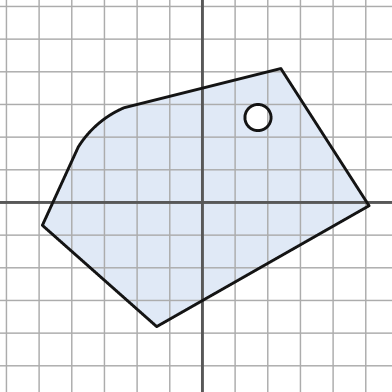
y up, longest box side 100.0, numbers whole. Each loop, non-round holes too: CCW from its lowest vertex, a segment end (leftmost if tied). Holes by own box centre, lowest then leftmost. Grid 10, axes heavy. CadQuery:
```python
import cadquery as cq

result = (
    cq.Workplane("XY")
    .moveTo(-14.0, -38.0)
    .lineTo(51.0, -1.0)
    .lineTo(24.0, 41.0)
    .lineTo(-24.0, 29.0)
    .threePointArc((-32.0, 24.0), (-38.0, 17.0))
    .lineTo(-49.0, -7.0)
    .close()
    .moveTo(17.0, 26.0)
    .circle(4.0)
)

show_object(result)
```